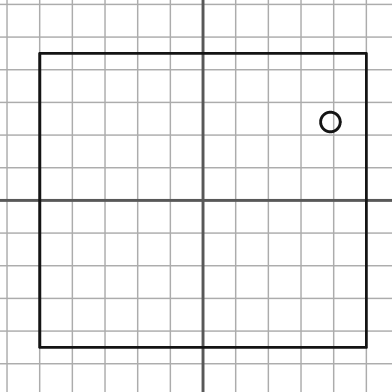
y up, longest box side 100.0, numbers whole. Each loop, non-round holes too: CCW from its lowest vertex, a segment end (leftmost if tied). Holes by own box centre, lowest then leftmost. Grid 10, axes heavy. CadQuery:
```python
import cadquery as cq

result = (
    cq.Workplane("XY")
    .moveTo(-50.0, -45.0)
    .lineTo(50.0, -45.0)
    .lineTo(50.0, 45.0)
    .lineTo(-50.0, 45.0)
    .close()
    .moveTo(39.0, 24.0)
    .circle(3.0)
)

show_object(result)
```